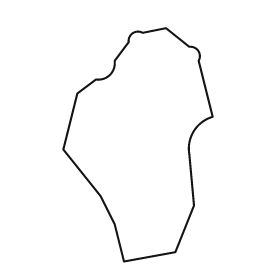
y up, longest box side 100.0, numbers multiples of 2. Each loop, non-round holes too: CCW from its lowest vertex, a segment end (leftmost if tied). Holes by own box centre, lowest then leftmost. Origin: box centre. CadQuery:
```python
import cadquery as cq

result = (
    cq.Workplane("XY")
    .moveTo(-6.0, -50.0)
    .lineTo(16.0, -46.0)
    .lineTo(24.0, -26.0)
    .lineTo(22.0, -4.0)
    .threePointArc((24.0, 6.0), (32.0, 12.0))
    .lineTo(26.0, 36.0)
    .threePointArc((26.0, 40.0), (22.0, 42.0))
    .lineTo(12.0, 50.0)
    .lineTo(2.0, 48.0)
    .threePointArc((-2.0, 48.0), (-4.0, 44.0))
    .lineTo(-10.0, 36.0)
    .threePointArc((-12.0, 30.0), (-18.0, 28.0))
    .lineTo(-26.0, 22.0)
    .lineTo(-32.0, -2.0)
    .lineTo(-16.0, -22.0)
    .lineTo(-10.0, -34.0)
    .close()
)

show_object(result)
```